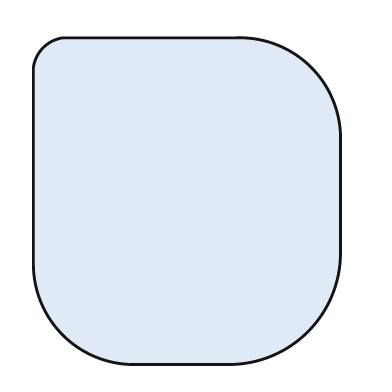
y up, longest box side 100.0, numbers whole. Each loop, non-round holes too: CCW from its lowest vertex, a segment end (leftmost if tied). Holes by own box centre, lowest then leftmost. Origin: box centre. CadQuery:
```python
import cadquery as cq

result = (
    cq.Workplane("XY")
    .moveTo(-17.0, -50.0)
    .lineTo(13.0, -50.0)
    .threePointArc((37.0, -40.0), (47.0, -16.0))
    .lineTo(47.0, 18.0)
    .threePointArc((38.0, 41.0), (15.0, 50.0))
    .lineTo(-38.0, 50.0)
    .threePointArc((-44.0, 47.0), (-47.0, 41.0))
    .lineTo(-47.0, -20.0)
    .threePointArc((-38.0, -41.0), (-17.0, -50.0))
    .close()
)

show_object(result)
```